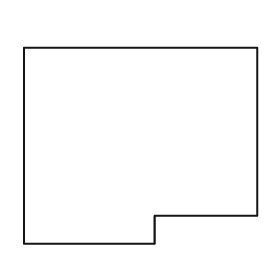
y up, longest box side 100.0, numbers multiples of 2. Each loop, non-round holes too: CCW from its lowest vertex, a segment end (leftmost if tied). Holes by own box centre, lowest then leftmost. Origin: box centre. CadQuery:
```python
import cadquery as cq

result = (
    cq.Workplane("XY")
    .moveTo(-50.0, -42.0)
    .lineTo(6.0, -42.0)
    .lineTo(6.0, -30.0)
    .lineTo(50.0, -30.0)
    .lineTo(50.0, 42.0)
    .lineTo(-50.0, 42.0)
    .close()
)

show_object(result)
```